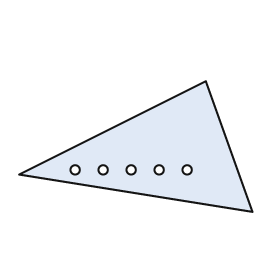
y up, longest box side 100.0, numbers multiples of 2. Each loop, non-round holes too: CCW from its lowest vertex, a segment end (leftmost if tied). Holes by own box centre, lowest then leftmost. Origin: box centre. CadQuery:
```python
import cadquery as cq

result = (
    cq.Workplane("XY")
    .moveTo(50.0, -28.0)
    .lineTo(30.0, 28.0)
    .lineTo(-50.0, -12.0)
    .close()
    .moveTo(-26.0, -10.0)
    .circle(2.0)
    .moveTo(-14.0, -10.0)
    .circle(2.0)
    .moveTo(-2.0, -10.0)
    .circle(2.0)
    .moveTo(10.0, -10.0)
    .circle(2.0)
    .moveTo(22.0, -10.0)
    .circle(2.0)
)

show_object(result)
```